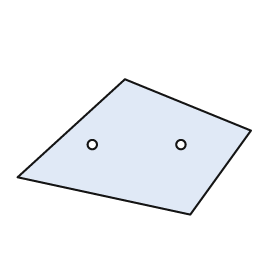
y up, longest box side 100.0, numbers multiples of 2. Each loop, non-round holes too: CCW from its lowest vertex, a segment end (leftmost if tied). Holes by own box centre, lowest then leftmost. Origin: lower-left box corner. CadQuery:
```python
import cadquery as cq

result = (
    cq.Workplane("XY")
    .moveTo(74.0, 0.0)
    .lineTo(100.0, 36.0)
    .lineTo(46.0, 58.0)
    .lineTo(0.0, 16.0)
    .close()
    .moveTo(32.0, 30.0)
    .circle(2.0)
    .moveTo(70.0, 30.0)
    .circle(2.0)
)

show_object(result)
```